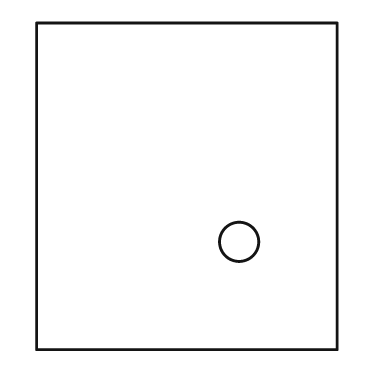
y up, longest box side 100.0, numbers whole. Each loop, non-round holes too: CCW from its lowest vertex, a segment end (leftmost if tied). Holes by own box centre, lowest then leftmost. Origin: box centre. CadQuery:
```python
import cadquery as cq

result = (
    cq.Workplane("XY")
    .moveTo(-46.0, -50.0)
    .lineTo(46.0, -50.0)
    .lineTo(46.0, 50.0)
    .lineTo(-46.0, 50.0)
    .close()
    .moveTo(16.0, -17.0)
    .circle(6.0)
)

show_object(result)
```